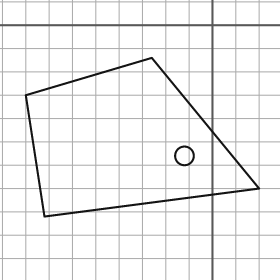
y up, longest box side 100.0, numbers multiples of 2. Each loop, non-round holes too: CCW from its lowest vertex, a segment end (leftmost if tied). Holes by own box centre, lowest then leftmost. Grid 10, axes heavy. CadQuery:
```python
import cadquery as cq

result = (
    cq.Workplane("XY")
    .moveTo(-72.0, -82.0)
    .lineTo(20.0, -70.0)
    .lineTo(-26.0, -14.0)
    .lineTo(-80.0, -30.0)
    .close()
    .moveTo(-12.0, -56.0)
    .circle(4.0)
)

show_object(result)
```